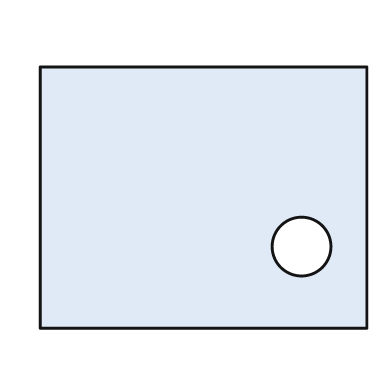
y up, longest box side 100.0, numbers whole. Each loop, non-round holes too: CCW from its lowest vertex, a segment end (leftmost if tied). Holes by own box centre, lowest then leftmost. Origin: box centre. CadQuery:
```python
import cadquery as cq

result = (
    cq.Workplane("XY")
    .moveTo(-50.0, -40.0)
    .lineTo(50.0, -40.0)
    .lineTo(50.0, 40.0)
    .lineTo(-50.0, 40.0)
    .close()
    .moveTo(30.0, -15.0)
    .circle(9.0)
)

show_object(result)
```